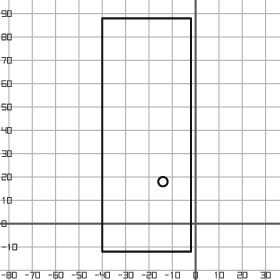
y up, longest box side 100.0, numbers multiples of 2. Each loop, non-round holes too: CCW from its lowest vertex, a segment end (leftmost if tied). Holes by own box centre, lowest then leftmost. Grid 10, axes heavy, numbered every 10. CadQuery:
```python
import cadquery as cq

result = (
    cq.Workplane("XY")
    .moveTo(-40.0, -12.0)
    .lineTo(-2.0, -12.0)
    .lineTo(-2.0, 88.0)
    .lineTo(-40.0, 88.0)
    .close()
    .moveTo(-14.0, 18.0)
    .circle(2.0)
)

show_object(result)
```